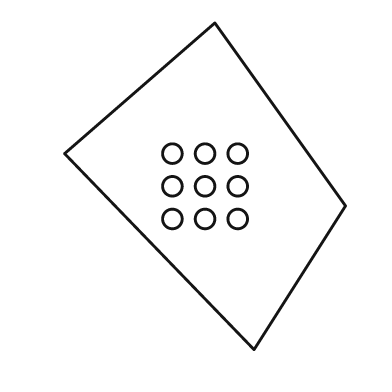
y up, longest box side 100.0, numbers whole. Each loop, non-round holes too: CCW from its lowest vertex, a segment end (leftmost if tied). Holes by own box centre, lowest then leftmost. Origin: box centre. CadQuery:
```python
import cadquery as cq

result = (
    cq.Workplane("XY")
    .moveTo(15.0, -50.0)
    .lineTo(43.0, -6.0)
    .lineTo(3.0, 50.0)
    .lineTo(-43.0, 10.0)
    .close()
    .moveTo(-10.0, -10.0)
    .circle(3.0)
    .moveTo(0.0, -10.0)
    .circle(3.0)
    .moveTo(10.0, -10.0)
    .circle(3.0)
    .moveTo(-10.0, 0.0)
    .circle(3.0)
    .moveTo(0.0, 0.0)
    .circle(3.0)
    .moveTo(10.0, 0.0)
    .circle(3.0)
    .moveTo(-10.0, 10.0)
    .circle(3.0)
    .moveTo(0.0, 10.0)
    .circle(3.0)
    .moveTo(10.0, 10.0)
    .circle(3.0)
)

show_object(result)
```